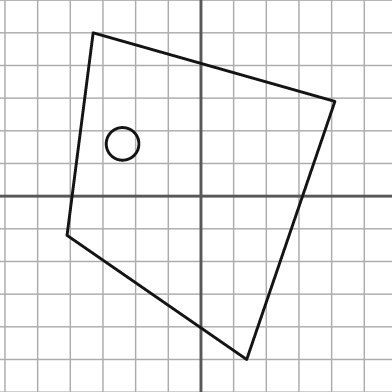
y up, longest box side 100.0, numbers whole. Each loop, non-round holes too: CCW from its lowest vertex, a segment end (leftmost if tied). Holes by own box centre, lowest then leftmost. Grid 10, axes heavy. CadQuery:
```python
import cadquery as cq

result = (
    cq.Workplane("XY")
    .moveTo(14.0, -50.0)
    .lineTo(41.0, 29.0)
    .lineTo(-33.0, 50.0)
    .lineTo(-41.0, -12.0)
    .close()
    .moveTo(-24.0, 16.0)
    .circle(5.0)
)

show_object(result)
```